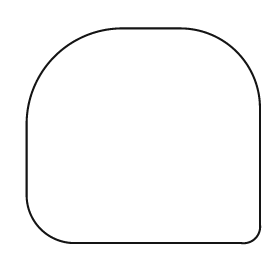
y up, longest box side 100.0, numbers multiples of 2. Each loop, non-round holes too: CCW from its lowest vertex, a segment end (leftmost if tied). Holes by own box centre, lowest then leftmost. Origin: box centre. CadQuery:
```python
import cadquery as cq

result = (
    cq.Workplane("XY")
    .moveTo(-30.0, -46.0)
    .lineTo(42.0, -46.0)
    .threePointArc((48.0, -44.0), (50.0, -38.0))
    .lineTo(50.0, 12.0)
    .threePointArc((40.0, 36.0), (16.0, 46.0))
    .lineTo(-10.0, 46.0)
    .threePointArc((-38.0, 34.0), (-50.0, 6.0))
    .lineTo(-50.0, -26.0)
    .threePointArc((-44.0, -40.0), (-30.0, -46.0))
    .close()
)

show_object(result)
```